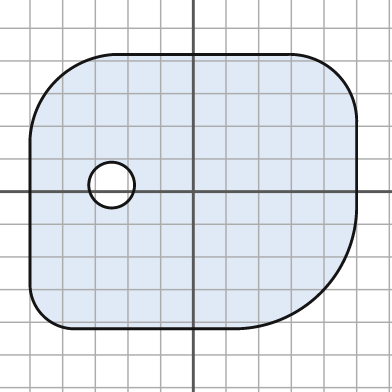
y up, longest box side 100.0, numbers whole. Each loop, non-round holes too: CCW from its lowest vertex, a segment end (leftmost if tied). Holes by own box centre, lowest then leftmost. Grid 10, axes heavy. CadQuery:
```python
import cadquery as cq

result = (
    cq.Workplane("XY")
    .moveTo(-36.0, -42.0)
    .lineTo(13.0, -42.0)
    .threePointArc((39.0, -31.0), (50.0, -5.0))
    .lineTo(50.0, 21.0)
    .threePointArc((44.0, 36.0), (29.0, 42.0))
    .lineTo(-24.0, 42.0)
    .threePointArc((-42.0, 34.0), (-50.0, 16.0))
    .lineTo(-50.0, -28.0)
    .threePointArc((-46.0, -38.0), (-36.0, -42.0))
    .close()
    .moveTo(-25.0, 2.0)
    .circle(7.0)
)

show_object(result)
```